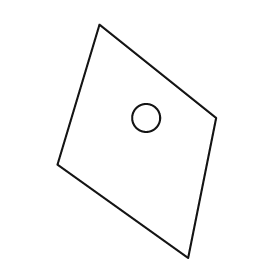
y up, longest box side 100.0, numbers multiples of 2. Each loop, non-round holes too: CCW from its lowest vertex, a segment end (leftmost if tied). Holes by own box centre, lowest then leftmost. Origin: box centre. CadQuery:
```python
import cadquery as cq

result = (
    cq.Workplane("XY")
    .moveTo(22.0, -50.0)
    .lineTo(34.0, 10.0)
    .lineTo(-16.0, 50.0)
    .lineTo(-34.0, -10.0)
    .close()
    .moveTo(4.0, 10.0)
    .circle(6.0)
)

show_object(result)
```